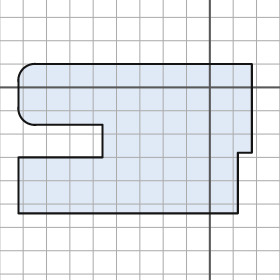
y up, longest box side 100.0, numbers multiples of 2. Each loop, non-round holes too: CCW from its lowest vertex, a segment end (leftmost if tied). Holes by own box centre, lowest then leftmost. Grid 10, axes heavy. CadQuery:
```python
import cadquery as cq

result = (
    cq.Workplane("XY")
    .moveTo(-82.0, -54.0)
    .lineTo(12.0, -54.0)
    .lineTo(12.0, -28.0)
    .lineTo(18.0, -28.0)
    .lineTo(18.0, 10.0)
    .lineTo(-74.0, 10.0)
    .threePointArc((-80.0, 8.0), (-82.0, 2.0))
    .lineTo(-82.0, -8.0)
    .threePointArc((-80.0, -14.0), (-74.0, -16.0))
    .lineTo(-46.0, -16.0)
    .lineTo(-46.0, -30.0)
    .lineTo(-82.0, -30.0)
    .close()
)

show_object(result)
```